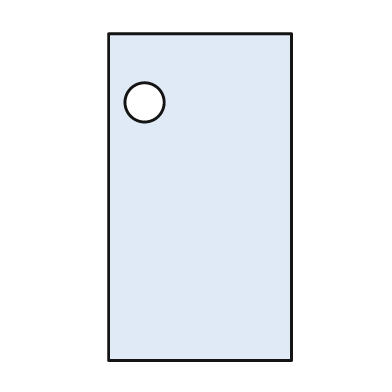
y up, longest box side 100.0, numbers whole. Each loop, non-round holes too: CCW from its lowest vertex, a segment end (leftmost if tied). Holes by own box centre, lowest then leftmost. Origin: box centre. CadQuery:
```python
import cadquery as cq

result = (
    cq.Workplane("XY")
    .moveTo(-28.0, -50.0)
    .lineTo(28.0, -50.0)
    .lineTo(28.0, 50.0)
    .lineTo(-28.0, 50.0)
    .close()
    .moveTo(-17.0, 29.0)
    .circle(6.0)
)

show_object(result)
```